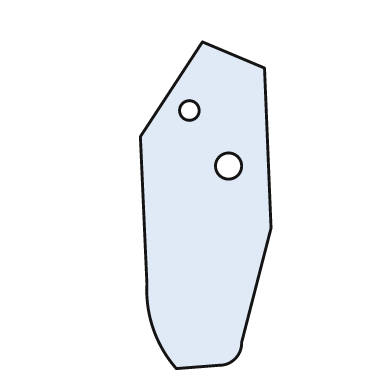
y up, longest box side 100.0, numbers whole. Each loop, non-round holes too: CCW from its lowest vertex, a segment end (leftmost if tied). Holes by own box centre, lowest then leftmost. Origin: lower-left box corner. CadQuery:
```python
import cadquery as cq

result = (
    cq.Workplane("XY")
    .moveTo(11.0, 0.0)
    .lineTo(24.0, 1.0)
    .threePointArc((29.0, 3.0), (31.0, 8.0))
    .lineTo(40.0, 43.0)
    .lineTo(38.0, 92.0)
    .lineTo(19.0, 100.0)
    .lineTo(0.0, 71.0)
    .lineTo(2.0, 26.0)
    .threePointArc((4.0, 12.0), (11.0, 0.0))
    .close()
    .moveTo(27.0, 62.0)
    .circle(4.0)
    .moveTo(15.0, 79.0)
    .circle(3.0)
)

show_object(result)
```